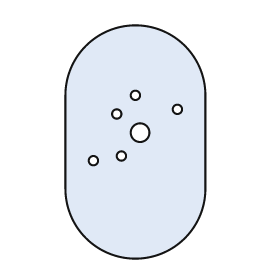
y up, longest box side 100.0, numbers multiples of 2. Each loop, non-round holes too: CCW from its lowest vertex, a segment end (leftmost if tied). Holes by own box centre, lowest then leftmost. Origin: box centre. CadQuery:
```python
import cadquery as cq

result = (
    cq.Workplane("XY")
    .moveTo(-30.0, -20.0)
    .threePointArc((0.0, -50.0), (30.0, -20.0))
    .lineTo(30.0, 20.0)
    .threePointArc((0.0, 50.0), (-30.0, 20.0))
    .close()
    .moveTo(-18.0, -8.0)
    .circle(2.0)
    .moveTo(-6.0, -6.0)
    .circle(2.0)
    .moveTo(2.0, 4.0)
    .circle(4.0)
    .moveTo(-8.0, 12.0)
    .circle(2.0)
    .moveTo(18.0, 14.0)
    .circle(2.0)
    .moveTo(0.0, 20.0)
    .circle(2.0)
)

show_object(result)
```